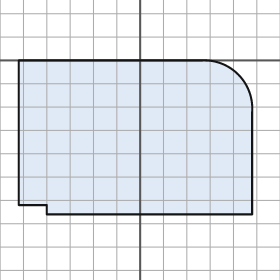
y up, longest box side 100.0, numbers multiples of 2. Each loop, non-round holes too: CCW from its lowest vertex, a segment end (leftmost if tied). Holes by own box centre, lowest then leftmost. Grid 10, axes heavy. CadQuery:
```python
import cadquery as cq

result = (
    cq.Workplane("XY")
    .moveTo(-40.0, -66.0)
    .lineTo(48.0, -66.0)
    .lineTo(48.0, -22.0)
    .threePointArc((42.0, -6.0), (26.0, 0.0))
    .lineTo(-52.0, 0.0)
    .lineTo(-52.0, -62.0)
    .lineTo(-40.0, -62.0)
    .close()
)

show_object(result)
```